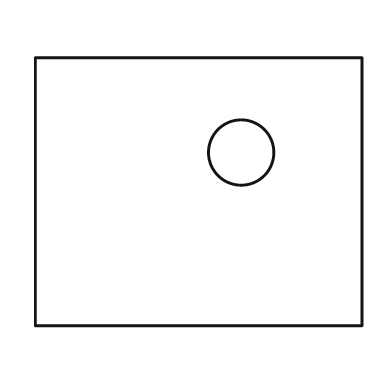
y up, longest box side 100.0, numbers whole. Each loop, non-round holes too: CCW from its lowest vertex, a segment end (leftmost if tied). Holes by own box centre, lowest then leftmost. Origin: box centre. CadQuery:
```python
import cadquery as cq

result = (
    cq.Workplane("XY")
    .moveTo(-50.0, -41.0)
    .lineTo(50.0, -41.0)
    .lineTo(50.0, 41.0)
    .lineTo(-50.0, 41.0)
    .close()
    .moveTo(13.0, 12.0)
    .circle(10.0)
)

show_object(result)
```